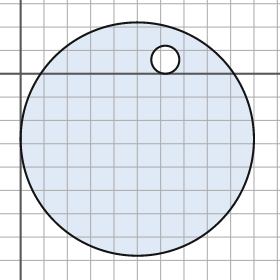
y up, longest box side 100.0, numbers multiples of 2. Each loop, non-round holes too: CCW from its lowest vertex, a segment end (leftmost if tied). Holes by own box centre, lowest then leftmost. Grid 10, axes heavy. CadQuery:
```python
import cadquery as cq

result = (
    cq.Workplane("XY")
    .moveTo(50.0, -28.0)
    .circle(50.0)
    .moveTo(62.0, 6.0)
    .circle(6.0)
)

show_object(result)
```